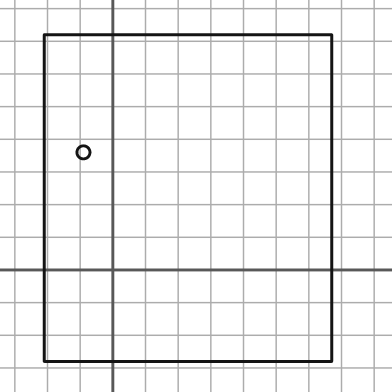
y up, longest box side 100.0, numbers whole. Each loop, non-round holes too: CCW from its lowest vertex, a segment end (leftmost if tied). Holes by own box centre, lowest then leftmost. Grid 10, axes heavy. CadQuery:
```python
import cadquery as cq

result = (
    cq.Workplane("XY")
    .moveTo(-21.0, -28.0)
    .lineTo(67.0, -28.0)
    .lineTo(67.0, 72.0)
    .lineTo(-21.0, 72.0)
    .close()
    .moveTo(-9.0, 36.0)
    .circle(2.0)
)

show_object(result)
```